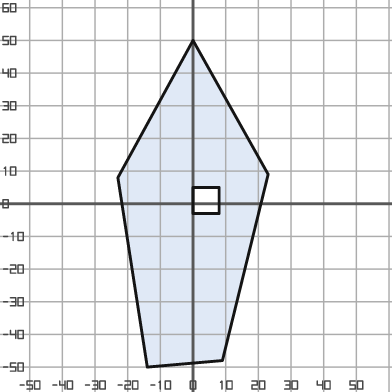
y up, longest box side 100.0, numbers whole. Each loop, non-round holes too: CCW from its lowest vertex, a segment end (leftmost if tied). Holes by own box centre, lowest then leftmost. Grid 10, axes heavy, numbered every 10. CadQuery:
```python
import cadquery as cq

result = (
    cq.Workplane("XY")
    .moveTo(-14.0, -50.0)
    .lineTo(9.0, -48.0)
    .lineTo(23.0, 9.0)
    .lineTo(0.0, 50.0)
    .lineTo(-23.0, 8.0)
    .close()
    .moveTo(0.0, -3.0)
    .lineTo(8.0, -3.0)
    .lineTo(8.0, 5.0)
    .lineTo(0.0, 5.0)
    .close()
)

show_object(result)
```